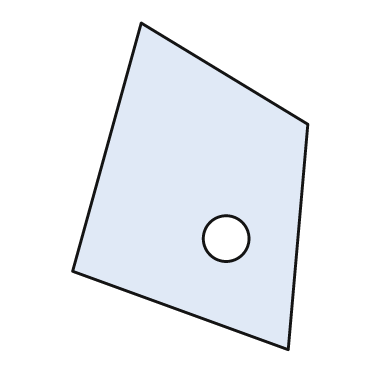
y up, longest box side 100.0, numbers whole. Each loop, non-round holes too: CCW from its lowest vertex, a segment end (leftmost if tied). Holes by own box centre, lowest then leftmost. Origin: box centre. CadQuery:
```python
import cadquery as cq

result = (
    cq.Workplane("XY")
    .moveTo(30.0, -50.0)
    .lineTo(36.0, 19.0)
    .lineTo(-15.0, 50.0)
    .lineTo(-36.0, -26.0)
    .close()
    .moveTo(11.0, -16.0)
    .circle(7.0)
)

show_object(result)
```